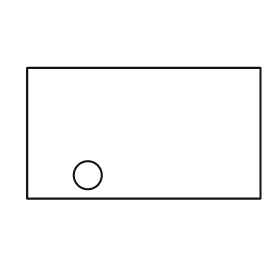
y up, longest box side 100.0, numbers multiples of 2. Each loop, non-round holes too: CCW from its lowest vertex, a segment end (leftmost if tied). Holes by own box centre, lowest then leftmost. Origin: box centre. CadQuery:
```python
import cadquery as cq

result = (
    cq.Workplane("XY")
    .moveTo(-50.0, -28.0)
    .lineTo(50.0, -28.0)
    .lineTo(50.0, 28.0)
    .lineTo(-50.0, 28.0)
    .close()
    .moveTo(-24.0, -18.0)
    .circle(6.0)
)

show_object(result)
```